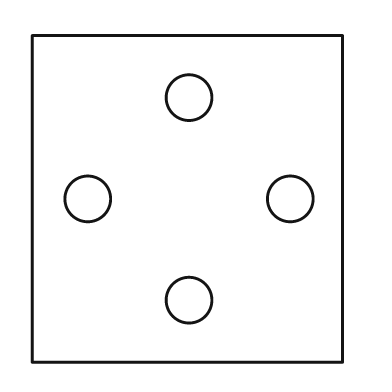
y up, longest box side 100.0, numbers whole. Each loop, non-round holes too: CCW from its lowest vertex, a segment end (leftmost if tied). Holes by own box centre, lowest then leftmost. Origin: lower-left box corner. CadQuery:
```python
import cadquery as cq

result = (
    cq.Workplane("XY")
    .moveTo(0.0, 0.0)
    .lineTo(95.0, 0.0)
    .lineTo(95.0, 100.0)
    .lineTo(0.0, 100.0)
    .close()
    .moveTo(48.0, 19.0)
    .circle(7.0)
    .moveTo(17.0, 50.0)
    .circle(7.0)
    .moveTo(79.0, 50.0)
    .circle(7.0)
    .moveTo(48.0, 81.0)
    .circle(7.0)
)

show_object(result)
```